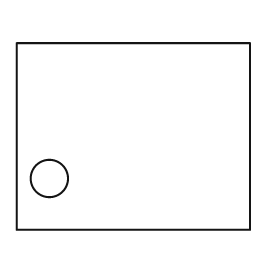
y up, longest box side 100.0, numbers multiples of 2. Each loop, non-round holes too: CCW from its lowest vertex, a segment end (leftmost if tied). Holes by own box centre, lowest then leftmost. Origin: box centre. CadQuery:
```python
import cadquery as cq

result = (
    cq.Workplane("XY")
    .moveTo(-50.0, -40.0)
    .lineTo(50.0, -40.0)
    .lineTo(50.0, 40.0)
    .lineTo(-50.0, 40.0)
    .close()
    .moveTo(-36.0, -18.0)
    .circle(8.0)
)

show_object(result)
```